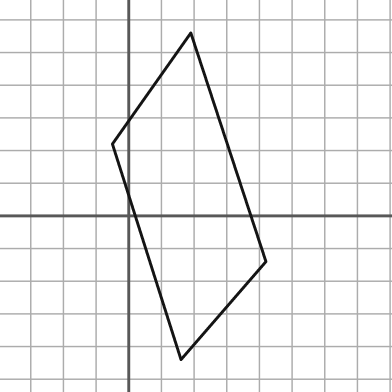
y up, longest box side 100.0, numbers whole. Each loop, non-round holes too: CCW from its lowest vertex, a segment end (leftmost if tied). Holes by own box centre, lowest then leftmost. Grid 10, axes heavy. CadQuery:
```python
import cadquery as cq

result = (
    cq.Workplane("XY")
    .moveTo(16.0, -44.0)
    .lineTo(42.0, -14.0)
    .lineTo(19.0, 56.0)
    .lineTo(-5.0, 22.0)
    .close()
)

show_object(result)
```